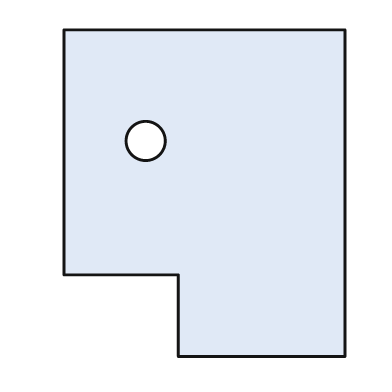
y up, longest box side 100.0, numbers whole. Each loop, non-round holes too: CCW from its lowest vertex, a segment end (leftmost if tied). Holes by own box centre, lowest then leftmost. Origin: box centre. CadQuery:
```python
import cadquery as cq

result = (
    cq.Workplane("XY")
    .moveTo(-8.0, -50.0)
    .lineTo(43.0, -50.0)
    .lineTo(43.0, 50.0)
    .lineTo(-43.0, 50.0)
    .lineTo(-43.0, -25.0)
    .lineTo(-8.0, -25.0)
    .close()
    .moveTo(-18.0, 16.0)
    .circle(6.0)
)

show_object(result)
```